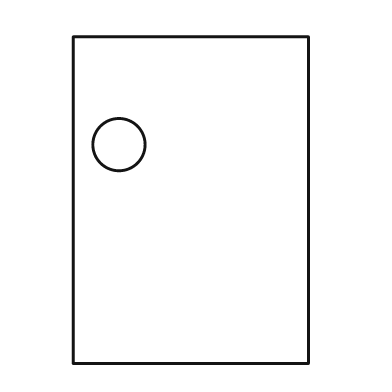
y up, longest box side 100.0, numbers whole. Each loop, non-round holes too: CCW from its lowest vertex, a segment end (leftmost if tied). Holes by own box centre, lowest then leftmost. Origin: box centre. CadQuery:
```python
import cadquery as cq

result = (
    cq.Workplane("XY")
    .moveTo(-36.0, -50.0)
    .lineTo(36.0, -50.0)
    .lineTo(36.0, 50.0)
    .lineTo(-36.0, 50.0)
    .close()
    .moveTo(-22.0, 17.0)
    .circle(8.0)
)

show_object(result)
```